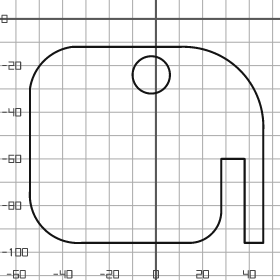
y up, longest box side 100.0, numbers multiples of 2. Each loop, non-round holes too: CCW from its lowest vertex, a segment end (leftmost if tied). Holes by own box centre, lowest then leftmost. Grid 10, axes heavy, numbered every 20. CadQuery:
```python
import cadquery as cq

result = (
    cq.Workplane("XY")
    .moveTo(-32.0, -96.0)
    .lineTo(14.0, -96.0)
    .threePointArc((24.0, -92.0), (28.0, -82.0))
    .lineTo(28.0, -60.0)
    .lineTo(38.0, -60.0)
    .lineTo(38.0, -96.0)
    .lineTo(46.0, -96.0)
    .lineTo(46.0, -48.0)
    .threePointArc((36.0, -22.0), (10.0, -12.0))
    .lineTo(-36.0, -12.0)
    .threePointArc((-48.0, -18.0), (-54.0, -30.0))
    .lineTo(-54.0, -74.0)
    .threePointArc((-48.0, -90.0), (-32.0, -96.0))
    .close()
    .moveTo(-2.0, -24.0)
    .circle(8.0)
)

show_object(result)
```